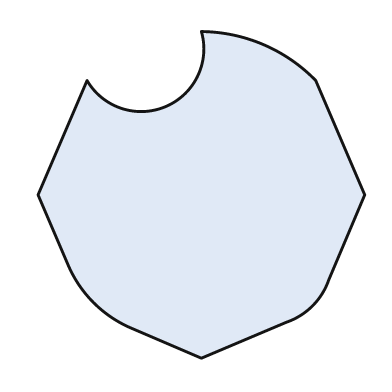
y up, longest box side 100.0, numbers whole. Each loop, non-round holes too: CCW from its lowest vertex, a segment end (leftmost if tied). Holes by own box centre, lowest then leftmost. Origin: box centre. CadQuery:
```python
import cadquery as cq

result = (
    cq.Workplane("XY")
    .moveTo(0.0, -50.0)
    .lineTo(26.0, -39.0)
    .threePointArc((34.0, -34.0), (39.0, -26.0))
    .lineTo(50.0, 0.0)
    .lineTo(35.0, 35.0)
    .threePointArc((19.0, 46.0), (0.0, 50.0))
    .threePointArc((-11.0, 27.0), (-35.0, 35.0))
    .lineTo(-50.0, 0.0)
    .lineTo(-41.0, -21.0)
    .threePointArc((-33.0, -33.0), (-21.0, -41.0))
    .close()
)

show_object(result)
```